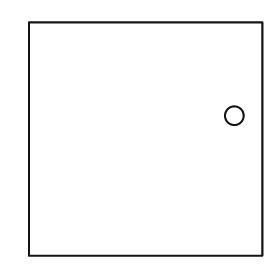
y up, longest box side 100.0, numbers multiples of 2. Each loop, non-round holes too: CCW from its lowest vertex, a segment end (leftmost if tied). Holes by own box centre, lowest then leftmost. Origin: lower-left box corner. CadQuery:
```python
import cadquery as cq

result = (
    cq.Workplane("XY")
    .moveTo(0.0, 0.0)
    .lineTo(100.0, 0.0)
    .lineTo(100.0, 100.0)
    .lineTo(0.0, 100.0)
    .close()
    .moveTo(88.0, 60.0)
    .circle(4.0)
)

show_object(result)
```